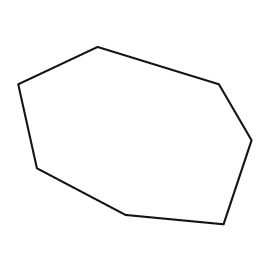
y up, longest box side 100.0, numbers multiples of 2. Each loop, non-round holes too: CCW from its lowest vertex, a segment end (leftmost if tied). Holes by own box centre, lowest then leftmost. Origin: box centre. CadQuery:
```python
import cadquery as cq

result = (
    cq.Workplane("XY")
    .moveTo(38.0, -38.0)
    .lineTo(50.0, -2.0)
    .lineTo(36.0, 22.0)
    .lineTo(-16.0, 38.0)
    .lineTo(-50.0, 22.0)
    .lineTo(-42.0, -14.0)
    .lineTo(-4.0, -34.0)
    .close()
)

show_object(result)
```